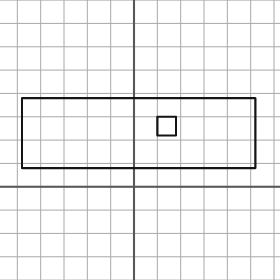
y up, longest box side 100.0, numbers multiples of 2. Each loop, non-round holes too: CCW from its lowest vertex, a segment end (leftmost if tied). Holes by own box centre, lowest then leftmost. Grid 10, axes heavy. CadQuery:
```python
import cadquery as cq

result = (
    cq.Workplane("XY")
    .moveTo(-48.0, 8.0)
    .lineTo(52.0, 8.0)
    .lineTo(52.0, 38.0)
    .lineTo(-48.0, 38.0)
    .close()
    .moveTo(10.0, 22.0)
    .lineTo(18.0, 22.0)
    .lineTo(18.0, 30.0)
    .lineTo(10.0, 30.0)
    .close()
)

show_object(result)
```